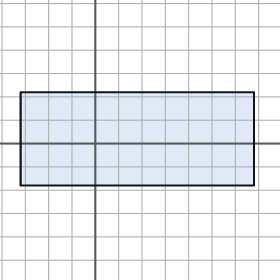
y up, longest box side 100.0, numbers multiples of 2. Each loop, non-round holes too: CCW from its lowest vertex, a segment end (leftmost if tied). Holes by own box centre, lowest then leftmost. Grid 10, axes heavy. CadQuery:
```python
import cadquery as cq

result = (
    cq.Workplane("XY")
    .moveTo(-32.0, -18.0)
    .lineTo(68.0, -18.0)
    .lineTo(68.0, 22.0)
    .lineTo(-32.0, 22.0)
    .close()
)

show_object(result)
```